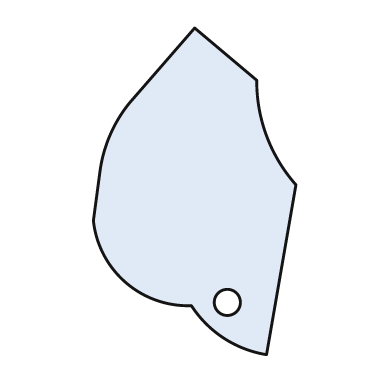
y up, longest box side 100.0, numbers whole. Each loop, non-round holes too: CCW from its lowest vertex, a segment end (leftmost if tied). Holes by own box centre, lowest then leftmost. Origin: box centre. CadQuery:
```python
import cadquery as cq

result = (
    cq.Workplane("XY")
    .moveTo(22.0, -50.0)
    .lineTo(31.0, 2.0)
    .threePointArc((22.0, 17.0), (19.0, 34.0))
    .lineTo(0.0, 50.0)
    .lineTo(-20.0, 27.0)
    .threePointArc((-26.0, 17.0), (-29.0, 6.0))
    .lineTo(-31.0, -9.0)
    .threePointArc((-21.0, -28.0), (-1.0, -35.0))
    .threePointArc((9.0, -45.0), (22.0, -50.0))
    .close()
    .moveTo(10.0, -34.0)
    .circle(4.0)
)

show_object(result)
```